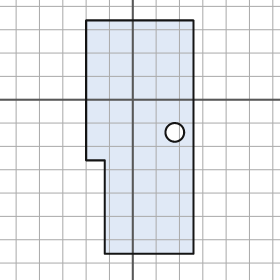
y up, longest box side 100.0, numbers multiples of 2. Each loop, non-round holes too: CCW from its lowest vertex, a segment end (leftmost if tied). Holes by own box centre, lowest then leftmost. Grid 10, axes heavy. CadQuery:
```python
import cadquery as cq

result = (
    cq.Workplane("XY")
    .moveTo(-12.0, -66.0)
    .lineTo(26.0, -66.0)
    .lineTo(26.0, 34.0)
    .lineTo(-20.0, 34.0)
    .lineTo(-20.0, -26.0)
    .lineTo(-12.0, -26.0)
    .close()
    .moveTo(18.0, -14.0)
    .circle(4.0)
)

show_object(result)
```